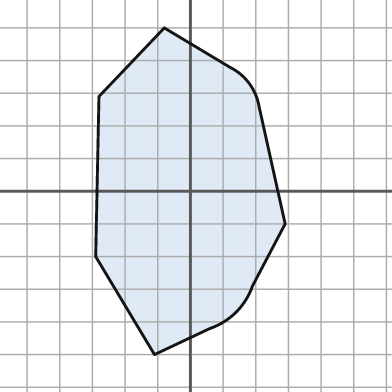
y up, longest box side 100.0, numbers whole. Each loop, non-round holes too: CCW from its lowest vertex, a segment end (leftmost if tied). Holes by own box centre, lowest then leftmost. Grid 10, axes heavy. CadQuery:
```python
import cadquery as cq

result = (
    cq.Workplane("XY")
    .moveTo(-11.0, -50.0)
    .lineTo(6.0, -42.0)
    .threePointArc((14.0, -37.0), (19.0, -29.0))
    .lineTo(29.0, -10.0)
    .lineTo(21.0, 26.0)
    .threePointArc((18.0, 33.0), (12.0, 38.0))
    .lineTo(-8.0, 50.0)
    .lineTo(-28.0, 29.0)
    .lineTo(-29.0, -20.0)
    .close()
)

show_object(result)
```